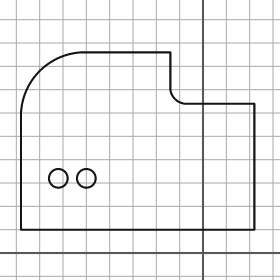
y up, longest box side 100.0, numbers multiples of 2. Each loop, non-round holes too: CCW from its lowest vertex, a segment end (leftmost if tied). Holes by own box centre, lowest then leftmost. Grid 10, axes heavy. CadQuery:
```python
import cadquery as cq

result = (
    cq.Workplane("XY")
    .moveTo(-78.0, 10.0)
    .lineTo(22.0, 10.0)
    .lineTo(22.0, 64.0)
    .lineTo(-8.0, 64.0)
    .threePointArc((-12.0, 66.0), (-14.0, 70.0))
    .lineTo(-14.0, 86.0)
    .lineTo(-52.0, 86.0)
    .threePointArc((-70.0, 78.0), (-78.0, 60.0))
    .close()
    .moveTo(-62.0, 32.0)
    .circle(4.0)
    .moveTo(-50.0, 32.0)
    .circle(4.0)
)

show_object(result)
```